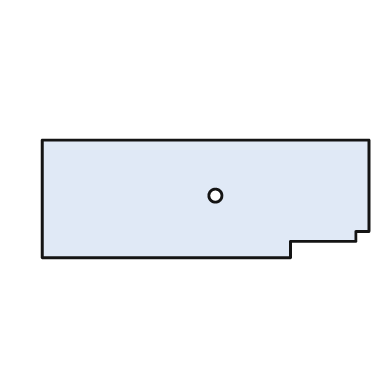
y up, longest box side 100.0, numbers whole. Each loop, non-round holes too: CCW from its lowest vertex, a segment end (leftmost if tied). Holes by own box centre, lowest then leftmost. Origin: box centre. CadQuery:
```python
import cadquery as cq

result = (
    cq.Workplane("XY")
    .moveTo(-50.0, -18.0)
    .lineTo(26.0, -18.0)
    .lineTo(26.0, -13.0)
    .lineTo(46.0, -13.0)
    .lineTo(46.0, -10.0)
    .lineTo(50.0, -10.0)
    .lineTo(50.0, 18.0)
    .lineTo(-50.0, 18.0)
    .close()
    .moveTo(3.0, 1.0)
    .circle(2.0)
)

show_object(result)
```